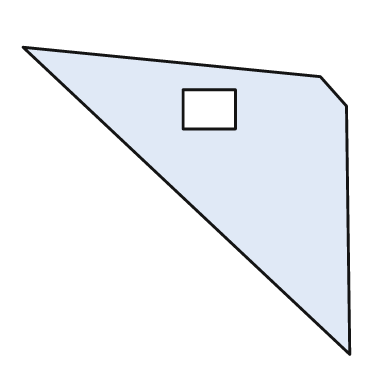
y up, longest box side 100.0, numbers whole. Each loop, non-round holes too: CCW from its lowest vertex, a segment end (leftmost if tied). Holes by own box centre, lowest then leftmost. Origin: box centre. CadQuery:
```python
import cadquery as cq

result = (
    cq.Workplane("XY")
    .moveTo(50.0, -47.0)
    .lineTo(49.0, 29.0)
    .lineTo(41.0, 38.0)
    .lineTo(-50.0, 47.0)
    .close()
    .moveTo(-1.0, 22.0)
    .lineTo(15.0, 22.0)
    .lineTo(15.0, 34.0)
    .lineTo(-1.0, 34.0)
    .close()
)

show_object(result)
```